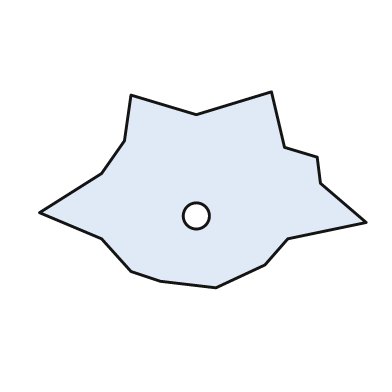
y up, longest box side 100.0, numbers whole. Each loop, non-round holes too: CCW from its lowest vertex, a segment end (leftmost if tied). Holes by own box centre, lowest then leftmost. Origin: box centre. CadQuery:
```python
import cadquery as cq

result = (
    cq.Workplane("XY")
    .moveTo(4.0, -30.0)
    .lineTo(19.0, -23.0)
    .lineTo(26.0, -15.0)
    .lineTo(50.0, -10.0)
    .lineTo(36.0, 2.0)
    .lineTo(35.0, 10.0)
    .lineTo(25.0, 13.0)
    .lineTo(21.0, 30.0)
    .lineTo(-2.0, 23.0)
    .lineTo(-22.0, 29.0)
    .lineTo(-24.0, 15.0)
    .lineTo(-31.0, 5.0)
    .lineTo(-50.0, -7.0)
    .lineTo(-31.0, -15.0)
    .lineTo(-22.0, -25.0)
    .lineTo(-13.0, -28.0)
    .close()
    .moveTo(-2.0, -8.0)
    .circle(4.0)
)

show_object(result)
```